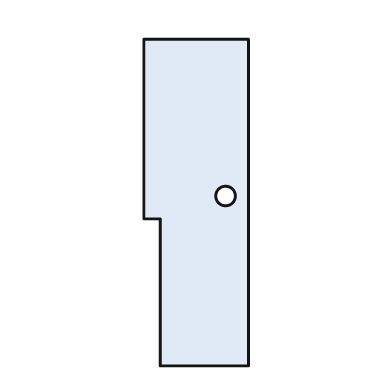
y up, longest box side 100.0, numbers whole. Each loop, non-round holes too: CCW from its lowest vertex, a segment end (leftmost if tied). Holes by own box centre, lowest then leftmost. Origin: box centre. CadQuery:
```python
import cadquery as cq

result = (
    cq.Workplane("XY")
    .moveTo(-11.0, -50.0)
    .lineTo(16.0, -50.0)
    .lineTo(16.0, 50.0)
    .lineTo(-16.0, 50.0)
    .lineTo(-16.0, -5.0)
    .lineTo(-11.0, -5.0)
    .close()
    .moveTo(9.0, 2.0)
    .circle(3.0)
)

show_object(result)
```